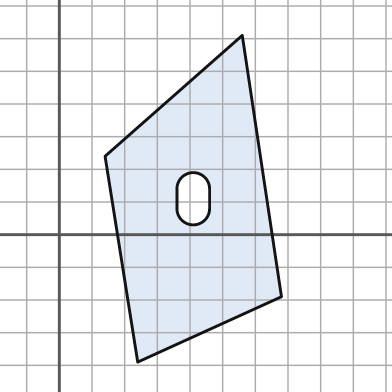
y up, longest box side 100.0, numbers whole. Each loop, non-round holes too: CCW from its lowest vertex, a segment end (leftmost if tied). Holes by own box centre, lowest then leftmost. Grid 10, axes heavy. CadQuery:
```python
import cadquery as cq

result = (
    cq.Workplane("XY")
    .moveTo(24.0, -39.0)
    .lineTo(68.0, -19.0)
    .lineTo(56.0, 61.0)
    .lineTo(14.0, 24.0)
    .close()
    .moveTo(36.0, 8.0)
    .threePointArc((41.0, 3.0), (46.0, 8.0))
    .lineTo(46.0, 14.0)
    .threePointArc((41.0, 19.0), (36.0, 14.0))
    .close()
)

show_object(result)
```